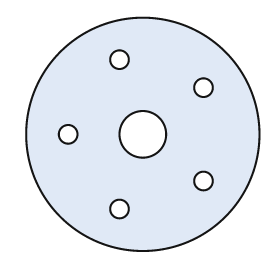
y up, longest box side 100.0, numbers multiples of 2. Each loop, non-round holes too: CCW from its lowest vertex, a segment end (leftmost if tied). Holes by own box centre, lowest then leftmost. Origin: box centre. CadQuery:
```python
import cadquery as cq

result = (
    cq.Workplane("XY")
    .moveTo(0.0, 0.0)
    .circle(50.0)
    .moveTo(-10.0, -32.0)
    .circle(4.0)
    .moveTo(26.0, -20.0)
    .circle(4.0)
    .moveTo(-32.0, 0.0)
    .circle(4.0)
    .moveTo(0.0, 0.0)
    .circle(10.0)
    .moveTo(26.0, 20.0)
    .circle(4.0)
    .moveTo(-10.0, 32.0)
    .circle(4.0)
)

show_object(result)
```